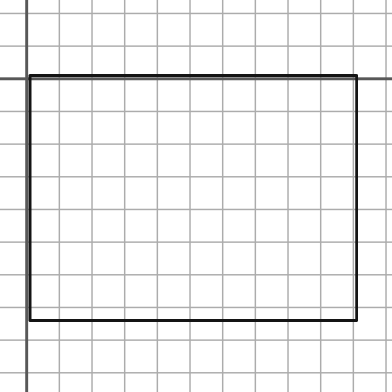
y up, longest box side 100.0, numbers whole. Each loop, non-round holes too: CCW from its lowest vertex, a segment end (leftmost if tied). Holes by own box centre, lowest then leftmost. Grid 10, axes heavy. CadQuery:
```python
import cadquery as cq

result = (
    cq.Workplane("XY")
    .moveTo(1.0, -74.0)
    .lineTo(101.0, -74.0)
    .lineTo(101.0, 1.0)
    .lineTo(1.0, 1.0)
    .close()
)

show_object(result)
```